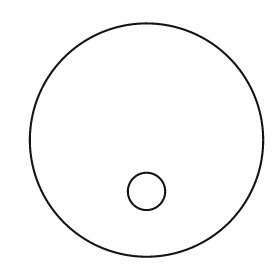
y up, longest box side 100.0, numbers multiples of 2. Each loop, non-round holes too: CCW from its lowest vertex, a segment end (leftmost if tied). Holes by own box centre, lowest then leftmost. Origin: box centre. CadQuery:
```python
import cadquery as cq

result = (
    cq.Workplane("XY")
    .moveTo(0.0, 0.0)
    .circle(50.0)
    .moveTo(0.0, -22.0)
    .circle(8.0)
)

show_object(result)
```